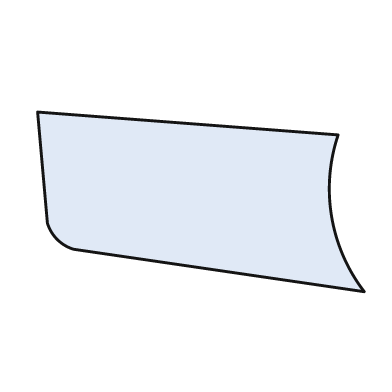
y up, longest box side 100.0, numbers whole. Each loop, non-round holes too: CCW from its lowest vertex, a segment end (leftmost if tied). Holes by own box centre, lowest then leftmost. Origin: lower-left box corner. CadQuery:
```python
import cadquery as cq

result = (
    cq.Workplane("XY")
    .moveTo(100.0, 0.0)
    .threePointArc((90.0, 23.0), (92.0, 48.0))
    .lineTo(0.0, 55.0)
    .lineTo(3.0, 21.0)
    .threePointArc((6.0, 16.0), (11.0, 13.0))
    .close()
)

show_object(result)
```